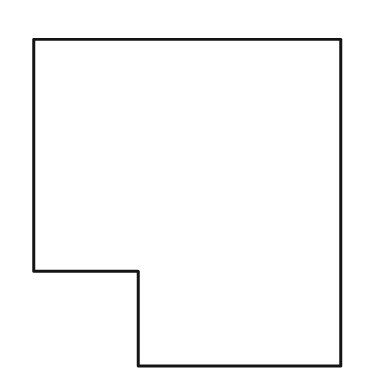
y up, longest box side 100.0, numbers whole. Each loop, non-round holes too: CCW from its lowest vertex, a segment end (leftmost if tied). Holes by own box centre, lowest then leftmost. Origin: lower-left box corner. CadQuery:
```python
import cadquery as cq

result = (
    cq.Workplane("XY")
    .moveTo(32.0, 0.0)
    .lineTo(94.0, 0.0)
    .lineTo(94.0, 100.0)
    .lineTo(0.0, 100.0)
    .lineTo(0.0, 29.0)
    .lineTo(32.0, 29.0)
    .close()
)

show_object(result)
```